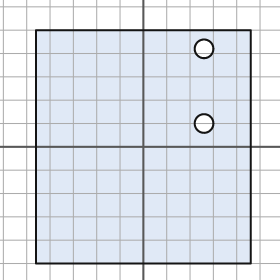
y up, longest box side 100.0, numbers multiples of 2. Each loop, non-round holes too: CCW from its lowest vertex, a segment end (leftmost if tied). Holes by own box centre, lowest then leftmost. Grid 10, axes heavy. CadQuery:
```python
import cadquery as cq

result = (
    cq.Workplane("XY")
    .moveTo(-46.0, -50.0)
    .lineTo(46.0, -50.0)
    .lineTo(46.0, 50.0)
    .lineTo(-46.0, 50.0)
    .close()
    .moveTo(26.0, 10.0)
    .circle(4.0)
    .moveTo(26.0, 42.0)
    .circle(4.0)
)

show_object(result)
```